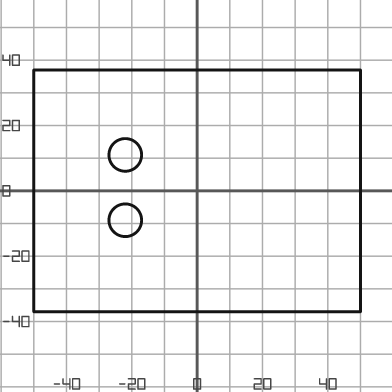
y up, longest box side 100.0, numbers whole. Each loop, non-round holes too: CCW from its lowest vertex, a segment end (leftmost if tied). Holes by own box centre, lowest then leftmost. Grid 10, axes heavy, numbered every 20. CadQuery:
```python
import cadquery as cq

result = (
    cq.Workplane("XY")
    .moveTo(-50.0, -37.0)
    .lineTo(50.0, -37.0)
    .lineTo(50.0, 37.0)
    .lineTo(-50.0, 37.0)
    .close()
    .moveTo(-22.0, -9.0)
    .circle(5.0)
    .moveTo(-22.0, 11.0)
    .circle(5.0)
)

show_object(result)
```